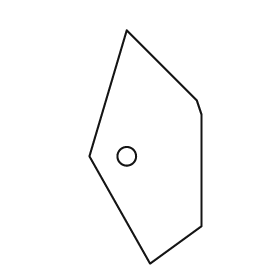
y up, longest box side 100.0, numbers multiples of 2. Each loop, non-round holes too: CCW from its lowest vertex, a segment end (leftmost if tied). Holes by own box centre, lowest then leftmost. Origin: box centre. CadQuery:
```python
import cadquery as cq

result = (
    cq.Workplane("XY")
    .moveTo(2.0, -50.0)
    .lineTo(24.0, -34.0)
    .lineTo(24.0, 14.0)
    .lineTo(22.0, 20.0)
    .lineTo(-8.0, 50.0)
    .lineTo(-24.0, -4.0)
    .close()
    .moveTo(-8.0, -4.0)
    .circle(4.0)
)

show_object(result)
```